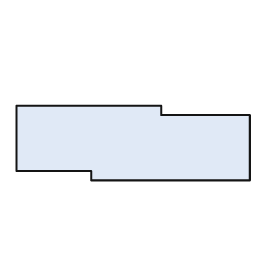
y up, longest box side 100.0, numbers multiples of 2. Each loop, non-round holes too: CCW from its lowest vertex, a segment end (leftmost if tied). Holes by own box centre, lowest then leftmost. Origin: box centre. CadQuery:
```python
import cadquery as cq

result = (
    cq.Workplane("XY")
    .moveTo(-18.0, -16.0)
    .lineTo(50.0, -16.0)
    .lineTo(50.0, 12.0)
    .lineTo(12.0, 12.0)
    .lineTo(12.0, 16.0)
    .lineTo(-50.0, 16.0)
    .lineTo(-50.0, -12.0)
    .lineTo(-18.0, -12.0)
    .close()
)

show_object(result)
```